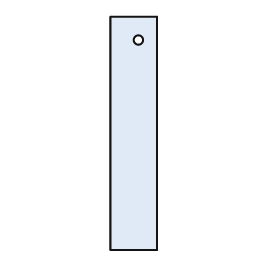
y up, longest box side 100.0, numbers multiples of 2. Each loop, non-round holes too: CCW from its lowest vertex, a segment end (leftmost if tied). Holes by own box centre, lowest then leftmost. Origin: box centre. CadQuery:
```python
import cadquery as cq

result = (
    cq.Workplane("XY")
    .moveTo(-10.0, -50.0)
    .lineTo(10.0, -50.0)
    .lineTo(10.0, 50.0)
    .lineTo(-10.0, 50.0)
    .close()
    .moveTo(2.0, 40.0)
    .circle(2.0)
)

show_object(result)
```